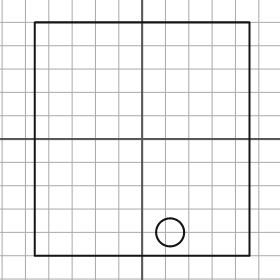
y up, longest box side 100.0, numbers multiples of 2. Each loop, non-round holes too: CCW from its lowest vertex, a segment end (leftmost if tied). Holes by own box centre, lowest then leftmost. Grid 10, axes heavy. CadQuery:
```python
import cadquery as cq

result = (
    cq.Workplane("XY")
    .moveTo(-46.0, -50.0)
    .lineTo(46.0, -50.0)
    .lineTo(46.0, 50.0)
    .lineTo(-46.0, 50.0)
    .close()
    .moveTo(12.0, -40.0)
    .circle(6.0)
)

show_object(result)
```